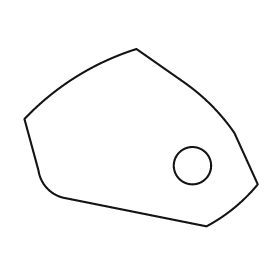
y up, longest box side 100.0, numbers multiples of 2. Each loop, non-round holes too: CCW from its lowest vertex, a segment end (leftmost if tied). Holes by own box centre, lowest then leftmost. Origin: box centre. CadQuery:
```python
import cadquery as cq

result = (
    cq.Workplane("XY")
    .moveTo(28.0, -38.0)
    .threePointArc((40.0, -30.0), (50.0, -20.0))
    .lineTo(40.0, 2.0)
    .threePointArc((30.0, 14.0), (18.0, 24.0))
    .lineTo(-2.0, 38.0)
    .threePointArc((-28.0, 26.0), (-50.0, 8.0))
    .lineTo(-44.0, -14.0)
    .threePointArc((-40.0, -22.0), (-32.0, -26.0))
    .close()
    .moveTo(22.0, -12.0)
    .circle(8.0)
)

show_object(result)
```